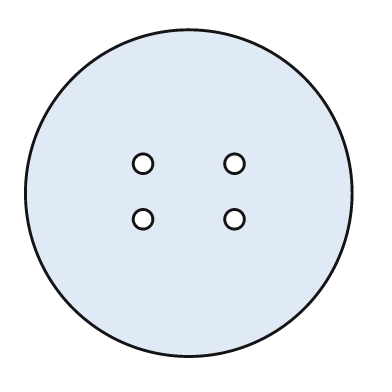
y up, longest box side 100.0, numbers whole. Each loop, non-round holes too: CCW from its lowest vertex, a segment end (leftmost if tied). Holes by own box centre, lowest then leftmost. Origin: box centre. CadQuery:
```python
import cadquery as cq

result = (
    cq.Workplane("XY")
    .moveTo(0.0, 0.0)
    .circle(50.0)
    .moveTo(-14.0, -8.0)
    .circle(3.0)
    .moveTo(14.0, -8.0)
    .circle(3.0)
    .moveTo(-14.0, 9.0)
    .circle(3.0)
    .moveTo(14.0, 9.0)
    .circle(3.0)
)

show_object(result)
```